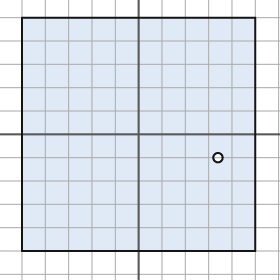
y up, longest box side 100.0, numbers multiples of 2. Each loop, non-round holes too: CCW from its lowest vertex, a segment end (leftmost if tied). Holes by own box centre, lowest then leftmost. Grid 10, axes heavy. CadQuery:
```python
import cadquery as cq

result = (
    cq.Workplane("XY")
    .moveTo(-50.0, -50.0)
    .lineTo(50.0, -50.0)
    .lineTo(50.0, 50.0)
    .lineTo(-50.0, 50.0)
    .close()
    .moveTo(34.0, -10.0)
    .circle(2.0)
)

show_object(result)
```